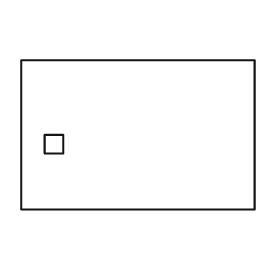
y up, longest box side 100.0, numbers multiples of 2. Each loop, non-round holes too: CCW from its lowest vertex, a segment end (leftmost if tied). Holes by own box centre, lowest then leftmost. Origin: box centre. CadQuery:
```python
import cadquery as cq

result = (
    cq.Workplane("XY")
    .moveTo(-50.0, -32.0)
    .lineTo(50.0, -32.0)
    .lineTo(50.0, 32.0)
    .lineTo(-50.0, 32.0)
    .close()
    .moveTo(-40.0, -8.0)
    .lineTo(-32.0, -8.0)
    .lineTo(-32.0, 0.0)
    .lineTo(-40.0, 0.0)
    .close()
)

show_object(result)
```